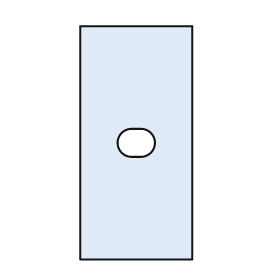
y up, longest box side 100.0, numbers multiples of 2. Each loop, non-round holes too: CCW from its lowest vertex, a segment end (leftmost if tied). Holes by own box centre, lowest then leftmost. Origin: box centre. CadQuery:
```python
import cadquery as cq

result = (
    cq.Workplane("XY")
    .moveTo(-24.0, -50.0)
    .lineTo(24.0, -50.0)
    .lineTo(24.0, 50.0)
    .lineTo(-24.0, 50.0)
    .close()
    .moveTo(-2.0, -6.0)
    .lineTo(2.0, -6.0)
    .threePointArc((8.0, 0.0), (2.0, 6.0))
    .lineTo(-2.0, 6.0)
    .threePointArc((-8.0, 0.0), (-2.0, -6.0))
    .close()
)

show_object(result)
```